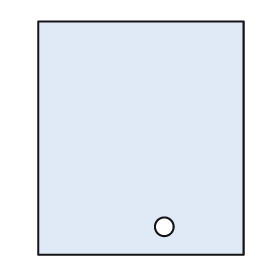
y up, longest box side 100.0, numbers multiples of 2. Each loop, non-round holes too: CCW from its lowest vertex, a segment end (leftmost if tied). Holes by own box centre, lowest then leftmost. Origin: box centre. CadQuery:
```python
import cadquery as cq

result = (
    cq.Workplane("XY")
    .moveTo(-44.0, -50.0)
    .lineTo(44.0, -50.0)
    .lineTo(44.0, 50.0)
    .lineTo(-44.0, 50.0)
    .close()
    .moveTo(10.0, -38.0)
    .circle(4.0)
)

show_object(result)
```